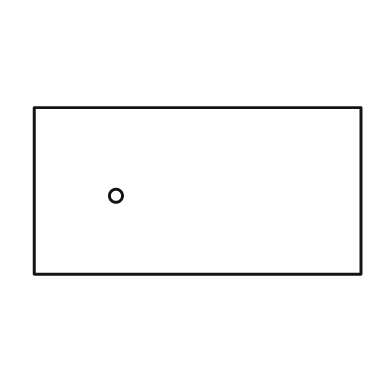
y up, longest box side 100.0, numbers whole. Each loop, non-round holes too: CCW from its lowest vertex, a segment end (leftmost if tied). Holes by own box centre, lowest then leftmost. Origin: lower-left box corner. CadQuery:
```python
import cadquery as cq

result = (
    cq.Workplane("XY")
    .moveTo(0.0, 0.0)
    .lineTo(100.0, 0.0)
    .lineTo(100.0, 51.0)
    .lineTo(0.0, 51.0)
    .close()
    .moveTo(25.0, 24.0)
    .circle(2.0)
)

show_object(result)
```